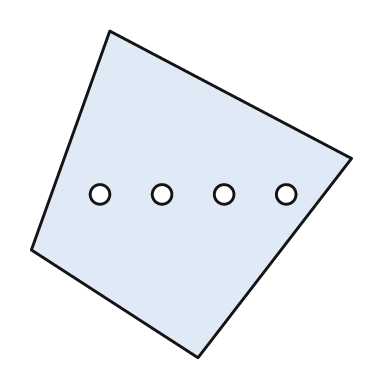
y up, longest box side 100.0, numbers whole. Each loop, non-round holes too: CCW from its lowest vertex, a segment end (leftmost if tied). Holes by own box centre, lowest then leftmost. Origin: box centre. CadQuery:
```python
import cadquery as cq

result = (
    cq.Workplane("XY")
    .moveTo(2.0, -50.0)
    .lineTo(49.0, 11.0)
    .lineTo(-25.0, 50.0)
    .lineTo(-49.0, -17.0)
    .close()
    .moveTo(-28.0, 0.0)
    .circle(3.0)
    .moveTo(-9.0, 0.0)
    .circle(3.0)
    .moveTo(10.0, 0.0)
    .circle(3.0)
    .moveTo(29.0, 0.0)
    .circle(3.0)
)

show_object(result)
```